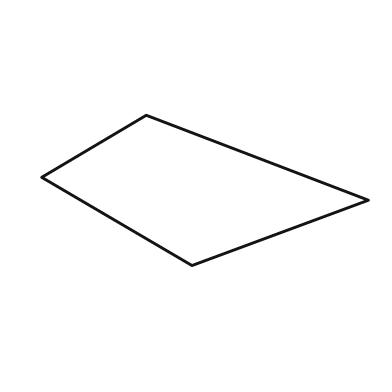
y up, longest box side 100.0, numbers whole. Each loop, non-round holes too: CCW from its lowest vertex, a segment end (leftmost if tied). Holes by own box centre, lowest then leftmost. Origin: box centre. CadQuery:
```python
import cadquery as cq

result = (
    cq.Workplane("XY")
    .moveTo(-4.0, -23.0)
    .lineTo(50.0, -3.0)
    .lineTo(-18.0, 23.0)
    .lineTo(-50.0, 4.0)
    .close()
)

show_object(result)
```